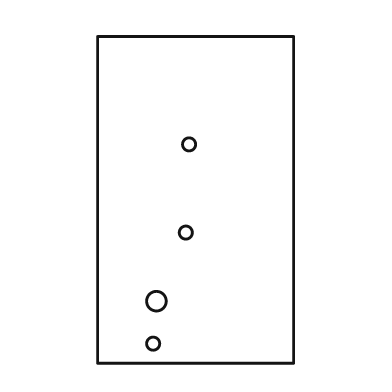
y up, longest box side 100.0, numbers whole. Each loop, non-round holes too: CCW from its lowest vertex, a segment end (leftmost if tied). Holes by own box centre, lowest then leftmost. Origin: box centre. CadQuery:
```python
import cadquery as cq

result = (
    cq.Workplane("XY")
    .moveTo(-30.0, -50.0)
    .lineTo(30.0, -50.0)
    .lineTo(30.0, 50.0)
    .lineTo(-30.0, 50.0)
    .close()
    .moveTo(-13.0, -44.0)
    .circle(2.0)
    .moveTo(-12.0, -31.0)
    .circle(3.0)
    .moveTo(-3.0, -10.0)
    .circle(2.0)
    .moveTo(-2.0, 17.0)
    .circle(2.0)
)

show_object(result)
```